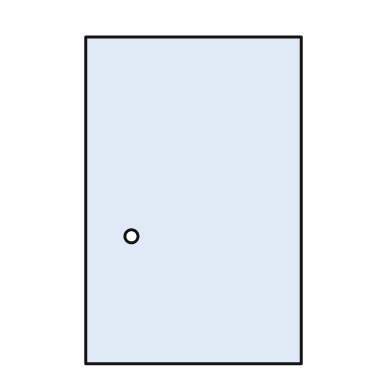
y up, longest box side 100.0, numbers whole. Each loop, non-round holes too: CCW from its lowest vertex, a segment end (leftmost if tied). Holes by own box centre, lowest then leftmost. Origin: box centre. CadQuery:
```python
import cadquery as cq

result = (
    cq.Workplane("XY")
    .moveTo(-33.0, -50.0)
    .lineTo(33.0, -50.0)
    .lineTo(33.0, 50.0)
    .lineTo(-33.0, 50.0)
    .close()
    .moveTo(-19.0, -11.0)
    .circle(2.0)
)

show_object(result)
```